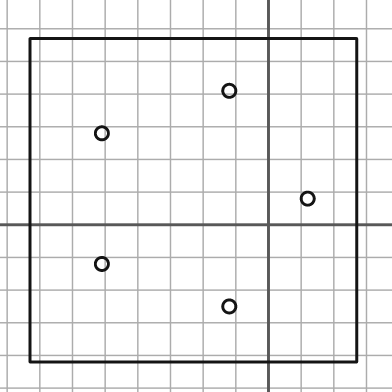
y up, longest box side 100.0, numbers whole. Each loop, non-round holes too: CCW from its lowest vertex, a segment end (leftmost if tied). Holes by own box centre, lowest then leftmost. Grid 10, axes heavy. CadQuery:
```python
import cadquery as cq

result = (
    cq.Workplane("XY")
    .moveTo(-73.0, -42.0)
    .lineTo(27.0, -42.0)
    .lineTo(27.0, 57.0)
    .lineTo(-73.0, 57.0)
    .close()
    .moveTo(-12.0, -25.0)
    .circle(2.0)
    .moveTo(-51.0, -12.0)
    .circle(2.0)
    .moveTo(12.0, 8.0)
    .circle(2.0)
    .moveTo(-51.0, 28.0)
    .circle(2.0)
    .moveTo(-12.0, 41.0)
    .circle(2.0)
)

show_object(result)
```